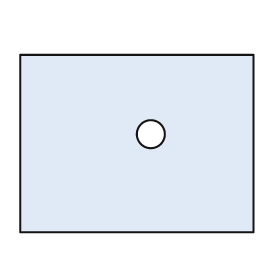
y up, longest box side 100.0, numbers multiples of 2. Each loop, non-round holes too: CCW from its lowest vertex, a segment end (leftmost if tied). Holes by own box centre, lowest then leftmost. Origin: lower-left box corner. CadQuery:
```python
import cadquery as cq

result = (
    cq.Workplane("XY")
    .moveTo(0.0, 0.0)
    .lineTo(100.0, 0.0)
    .lineTo(100.0, 76.0)
    .lineTo(0.0, 76.0)
    .close()
    .moveTo(56.0, 42.0)
    .circle(6.0)
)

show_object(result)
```